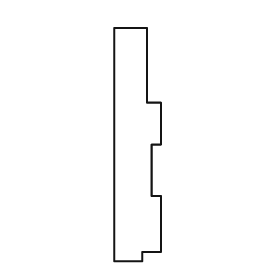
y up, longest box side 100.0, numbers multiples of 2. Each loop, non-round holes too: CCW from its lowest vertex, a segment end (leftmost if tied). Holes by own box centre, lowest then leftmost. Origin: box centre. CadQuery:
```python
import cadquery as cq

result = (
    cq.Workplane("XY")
    .moveTo(-10.0, -50.0)
    .lineTo(2.0, -50.0)
    .lineTo(2.0, -46.0)
    .lineTo(10.0, -46.0)
    .lineTo(10.0, -22.0)
    .lineTo(6.0, -22.0)
    .lineTo(6.0, 0.0)
    .lineTo(10.0, 0.0)
    .lineTo(10.0, 18.0)
    .lineTo(4.0, 18.0)
    .lineTo(4.0, 50.0)
    .lineTo(-10.0, 50.0)
    .close()
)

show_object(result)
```